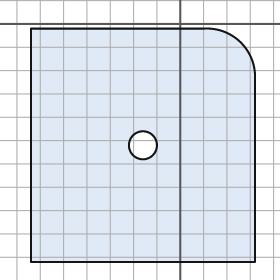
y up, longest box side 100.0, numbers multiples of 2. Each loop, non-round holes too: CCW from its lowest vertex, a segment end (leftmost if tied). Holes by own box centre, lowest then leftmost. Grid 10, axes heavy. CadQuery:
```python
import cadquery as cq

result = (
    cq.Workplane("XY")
    .moveTo(-64.0, -102.0)
    .lineTo(32.0, -102.0)
    .lineTo(32.0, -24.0)
    .threePointArc((26.0, -8.0), (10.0, -2.0))
    .lineTo(-64.0, -2.0)
    .close()
    .moveTo(-16.0, -52.0)
    .circle(6.0)
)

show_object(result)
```